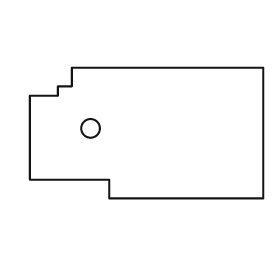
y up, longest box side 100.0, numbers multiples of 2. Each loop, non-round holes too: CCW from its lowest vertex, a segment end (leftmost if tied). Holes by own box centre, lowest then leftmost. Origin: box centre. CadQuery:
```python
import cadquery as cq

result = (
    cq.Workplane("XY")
    .moveTo(-16.0, -28.0)
    .lineTo(50.0, -28.0)
    .lineTo(50.0, 28.0)
    .lineTo(-32.0, 28.0)
    .lineTo(-32.0, 20.0)
    .lineTo(-38.0, 20.0)
    .lineTo(-38.0, 16.0)
    .lineTo(-50.0, 16.0)
    .lineTo(-50.0, -20.0)
    .lineTo(-16.0, -20.0)
    .close()
    .moveTo(-24.0, 2.0)
    .circle(4.0)
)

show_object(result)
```